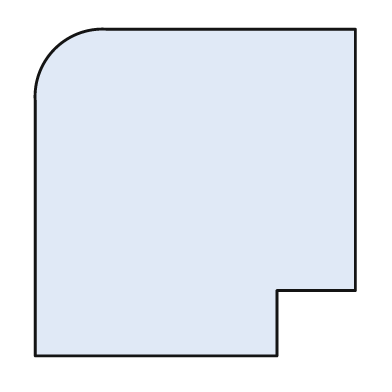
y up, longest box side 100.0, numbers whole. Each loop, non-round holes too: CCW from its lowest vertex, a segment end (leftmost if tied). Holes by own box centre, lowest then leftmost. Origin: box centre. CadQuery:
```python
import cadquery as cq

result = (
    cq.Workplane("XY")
    .moveTo(-49.0, -50.0)
    .lineTo(25.0, -50.0)
    .lineTo(25.0, -30.0)
    .lineTo(49.0, -30.0)
    .lineTo(49.0, 50.0)
    .lineTo(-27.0, 50.0)
    .threePointArc((-43.0, 44.0), (-49.0, 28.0))
    .close()
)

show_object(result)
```